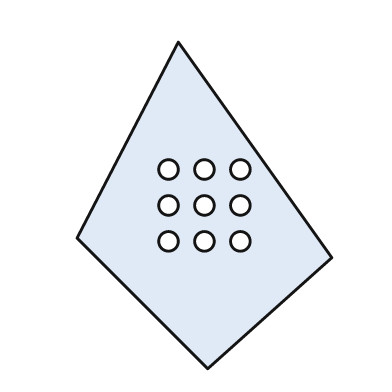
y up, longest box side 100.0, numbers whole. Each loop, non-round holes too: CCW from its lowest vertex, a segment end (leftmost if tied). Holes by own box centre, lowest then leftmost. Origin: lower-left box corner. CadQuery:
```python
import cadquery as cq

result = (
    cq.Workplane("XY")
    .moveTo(40.0, 0.0)
    .lineTo(78.0, 34.0)
    .lineTo(31.0, 100.0)
    .lineTo(0.0, 40.0)
    .close()
    .moveTo(28.0, 39.0)
    .circle(3.0)
    .moveTo(39.0, 39.0)
    .circle(3.0)
    .moveTo(50.0, 39.0)
    .circle(3.0)
    .moveTo(28.0, 50.0)
    .circle(3.0)
    .moveTo(39.0, 50.0)
    .circle(3.0)
    .moveTo(50.0, 50.0)
    .circle(3.0)
    .moveTo(28.0, 61.0)
    .circle(3.0)
    .moveTo(39.0, 61.0)
    .circle(3.0)
    .moveTo(50.0, 61.0)
    .circle(3.0)
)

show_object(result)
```